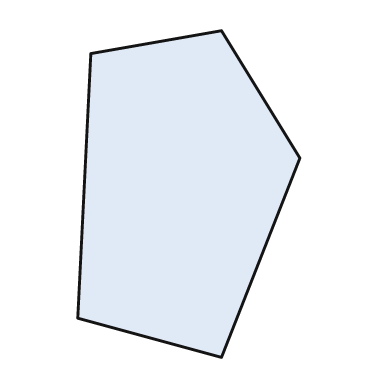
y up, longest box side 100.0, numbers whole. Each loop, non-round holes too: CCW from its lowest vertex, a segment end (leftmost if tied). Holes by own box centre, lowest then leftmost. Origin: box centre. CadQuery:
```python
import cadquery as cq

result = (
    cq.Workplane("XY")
    .moveTo(10.0, -50.0)
    .lineTo(34.0, 11.0)
    .lineTo(10.0, 50.0)
    .lineTo(-30.0, 43.0)
    .lineTo(-34.0, -38.0)
    .close()
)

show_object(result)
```